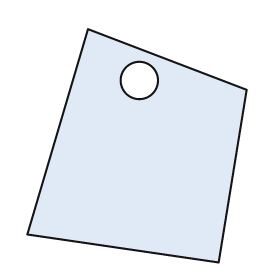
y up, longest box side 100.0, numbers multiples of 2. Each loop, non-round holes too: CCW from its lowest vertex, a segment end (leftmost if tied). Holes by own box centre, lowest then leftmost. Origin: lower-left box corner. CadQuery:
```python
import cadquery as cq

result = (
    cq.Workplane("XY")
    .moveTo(82.0, 0.0)
    .lineTo(94.0, 74.0)
    .lineTo(26.0, 100.0)
    .lineTo(0.0, 12.0)
    .close()
    .moveTo(48.0, 78.0)
    .circle(8.0)
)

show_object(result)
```